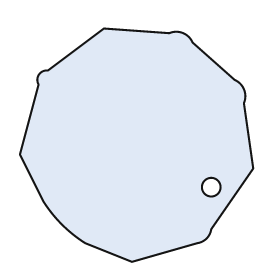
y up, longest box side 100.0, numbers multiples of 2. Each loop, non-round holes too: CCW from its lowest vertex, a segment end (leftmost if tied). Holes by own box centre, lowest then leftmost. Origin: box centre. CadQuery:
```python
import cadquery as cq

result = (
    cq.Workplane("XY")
    .moveTo(-2.0, -50.0)
    .lineTo(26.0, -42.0)
    .threePointArc((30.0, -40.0), (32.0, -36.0))
    .lineTo(50.0, -10.0)
    .lineTo(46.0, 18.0)
    .threePointArc((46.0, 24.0), (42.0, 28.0))
    .lineTo(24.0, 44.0)
    .threePointArc((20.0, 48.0), (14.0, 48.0))
    .lineTo(-14.0, 50.0)
    .lineTo(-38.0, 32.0)
    .threePointArc((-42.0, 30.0), (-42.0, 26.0))
    .lineTo(-50.0, -4.0)
    .lineTo(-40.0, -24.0)
    .threePointArc((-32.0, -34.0), (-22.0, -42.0))
    .close()
    .moveTo(32.0, -18.0)
    .circle(4.0)
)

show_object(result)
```